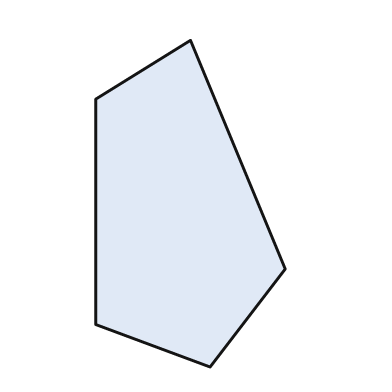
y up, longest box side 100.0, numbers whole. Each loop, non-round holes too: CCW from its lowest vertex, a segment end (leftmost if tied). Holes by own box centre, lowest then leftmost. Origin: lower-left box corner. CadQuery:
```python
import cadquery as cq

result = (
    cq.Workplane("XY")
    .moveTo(35.0, 0.0)
    .lineTo(58.0, 30.0)
    .lineTo(29.0, 100.0)
    .lineTo(0.0, 82.0)
    .lineTo(0.0, 13.0)
    .close()
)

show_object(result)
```